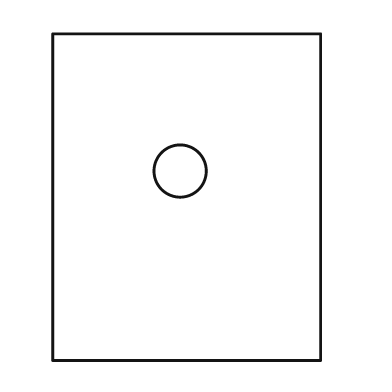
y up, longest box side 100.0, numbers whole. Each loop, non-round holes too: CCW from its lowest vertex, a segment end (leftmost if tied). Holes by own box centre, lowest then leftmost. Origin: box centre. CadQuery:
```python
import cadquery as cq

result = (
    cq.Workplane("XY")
    .moveTo(-41.0, -50.0)
    .lineTo(41.0, -50.0)
    .lineTo(41.0, 50.0)
    .lineTo(-41.0, 50.0)
    .close()
    .moveTo(-2.0, 8.0)
    .circle(8.0)
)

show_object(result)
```